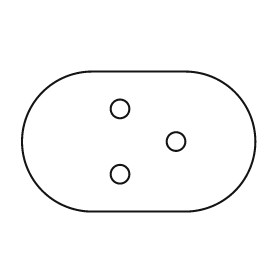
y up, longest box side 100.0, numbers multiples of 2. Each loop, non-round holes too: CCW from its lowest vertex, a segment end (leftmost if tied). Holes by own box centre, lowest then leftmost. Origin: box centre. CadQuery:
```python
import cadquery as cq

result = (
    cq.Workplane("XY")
    .moveTo(-20.0, -30.0)
    .lineTo(20.0, -30.0)
    .threePointArc((50.0, 0.0), (20.0, 30.0))
    .lineTo(-20.0, 30.0)
    .threePointArc((-50.0, 0.0), (-20.0, -30.0))
    .close()
    .moveTo(-8.0, -14.0)
    .circle(4.0)
    .moveTo(16.0, 0.0)
    .circle(4.0)
    .moveTo(-8.0, 14.0)
    .circle(4.0)
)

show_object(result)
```